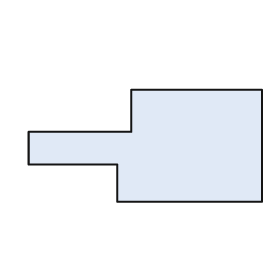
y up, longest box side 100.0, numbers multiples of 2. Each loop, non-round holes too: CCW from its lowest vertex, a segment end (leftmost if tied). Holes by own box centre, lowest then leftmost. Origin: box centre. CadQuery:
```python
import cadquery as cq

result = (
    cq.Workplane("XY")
    .moveTo(-12.0, -24.0)
    .lineTo(50.0, -24.0)
    .lineTo(50.0, 24.0)
    .lineTo(-6.0, 24.0)
    .lineTo(-6.0, 6.0)
    .lineTo(-50.0, 6.0)
    .lineTo(-50.0, -8.0)
    .lineTo(-12.0, -8.0)
    .close()
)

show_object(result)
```